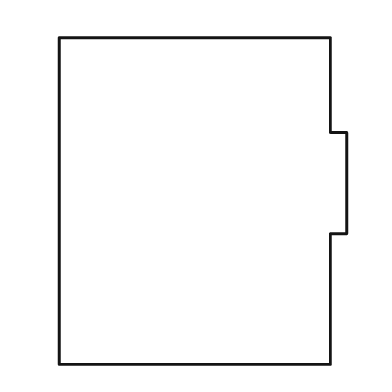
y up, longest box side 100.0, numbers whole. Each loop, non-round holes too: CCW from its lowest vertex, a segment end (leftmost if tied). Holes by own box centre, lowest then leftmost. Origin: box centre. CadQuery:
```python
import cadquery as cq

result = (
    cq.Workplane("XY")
    .moveTo(-44.0, -50.0)
    .lineTo(39.0, -50.0)
    .lineTo(39.0, -10.0)
    .lineTo(44.0, -10.0)
    .lineTo(44.0, 21.0)
    .lineTo(39.0, 21.0)
    .lineTo(39.0, 50.0)
    .lineTo(-44.0, 50.0)
    .close()
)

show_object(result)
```